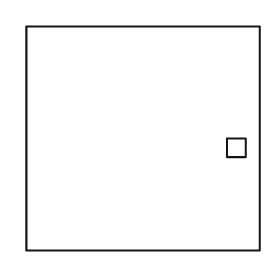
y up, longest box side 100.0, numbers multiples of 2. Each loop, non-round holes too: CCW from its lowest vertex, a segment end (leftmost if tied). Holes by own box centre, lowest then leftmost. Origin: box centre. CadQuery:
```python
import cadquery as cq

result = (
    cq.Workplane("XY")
    .moveTo(-50.0, -48.0)
    .lineTo(50.0, -48.0)
    .lineTo(50.0, 48.0)
    .lineTo(-50.0, 48.0)
    .close()
    .moveTo(36.0, -8.0)
    .lineTo(44.0, -8.0)
    .lineTo(44.0, 0.0)
    .lineTo(36.0, 0.0)
    .close()
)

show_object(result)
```